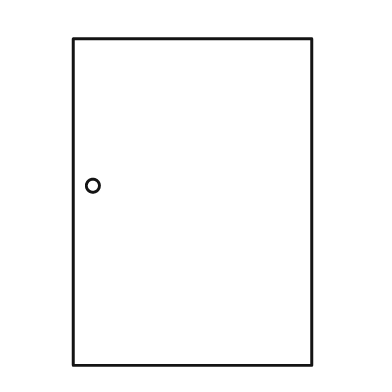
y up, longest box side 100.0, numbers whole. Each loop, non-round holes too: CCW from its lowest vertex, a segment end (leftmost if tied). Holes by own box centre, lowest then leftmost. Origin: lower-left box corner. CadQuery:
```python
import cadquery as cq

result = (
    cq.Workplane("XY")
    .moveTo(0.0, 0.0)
    .lineTo(73.0, 0.0)
    .lineTo(73.0, 100.0)
    .lineTo(0.0, 100.0)
    .close()
    .moveTo(6.0, 55.0)
    .circle(2.0)
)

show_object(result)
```